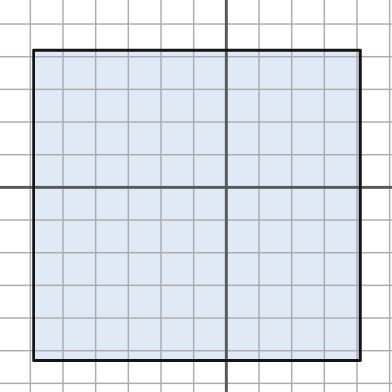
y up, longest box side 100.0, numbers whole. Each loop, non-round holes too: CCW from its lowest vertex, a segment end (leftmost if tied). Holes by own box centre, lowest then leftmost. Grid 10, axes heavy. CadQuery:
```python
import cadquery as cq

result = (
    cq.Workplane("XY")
    .moveTo(-59.0, -53.0)
    .lineTo(41.0, -53.0)
    .lineTo(41.0, 42.0)
    .lineTo(-59.0, 42.0)
    .close()
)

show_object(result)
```